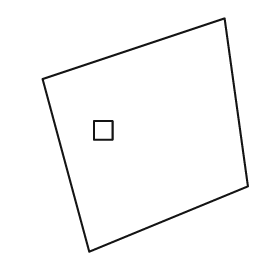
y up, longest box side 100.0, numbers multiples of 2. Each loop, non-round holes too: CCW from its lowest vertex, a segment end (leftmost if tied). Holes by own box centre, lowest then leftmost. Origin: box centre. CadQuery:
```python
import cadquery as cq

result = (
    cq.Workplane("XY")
    .moveTo(-24.0, -50.0)
    .lineTo(44.0, -22.0)
    .lineTo(34.0, 50.0)
    .lineTo(-44.0, 24.0)
    .close()
    .moveTo(-22.0, -2.0)
    .lineTo(-14.0, -2.0)
    .lineTo(-14.0, 6.0)
    .lineTo(-22.0, 6.0)
    .close()
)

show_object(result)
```